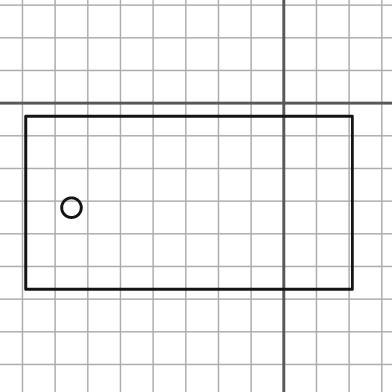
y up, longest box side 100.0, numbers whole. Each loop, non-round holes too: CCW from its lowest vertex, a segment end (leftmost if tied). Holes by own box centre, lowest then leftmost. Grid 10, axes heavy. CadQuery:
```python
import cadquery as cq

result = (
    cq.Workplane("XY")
    .moveTo(-79.0, -57.0)
    .lineTo(21.0, -57.0)
    .lineTo(21.0, -4.0)
    .lineTo(-79.0, -4.0)
    .close()
    .moveTo(-65.0, -32.0)
    .circle(3.0)
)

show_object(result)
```